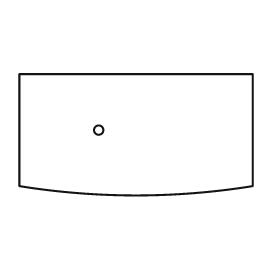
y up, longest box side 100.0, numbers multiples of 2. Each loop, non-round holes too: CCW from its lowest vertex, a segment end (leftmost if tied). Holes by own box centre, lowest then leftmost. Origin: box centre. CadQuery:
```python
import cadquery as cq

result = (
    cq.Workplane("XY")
    .moveTo(-50.0, -22.0)
    .threePointArc((0.0, -26.0), (50.0, -22.0))
    .lineTo(50.0, 26.0)
    .lineTo(-50.0, 26.0)
    .close()
    .moveTo(-16.0, 2.0)
    .circle(2.0)
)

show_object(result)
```